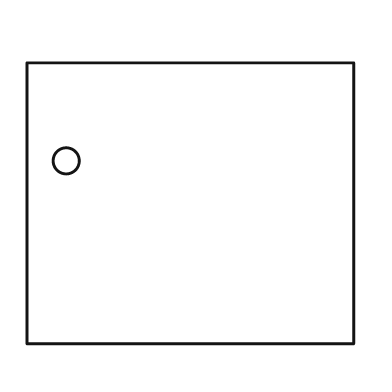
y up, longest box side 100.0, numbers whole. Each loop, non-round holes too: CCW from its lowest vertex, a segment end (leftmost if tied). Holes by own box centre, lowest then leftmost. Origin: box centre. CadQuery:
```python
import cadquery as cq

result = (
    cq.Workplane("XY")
    .moveTo(-50.0, -43.0)
    .lineTo(50.0, -43.0)
    .lineTo(50.0, 43.0)
    .lineTo(-50.0, 43.0)
    .close()
    .moveTo(-38.0, 13.0)
    .circle(4.0)
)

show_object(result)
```